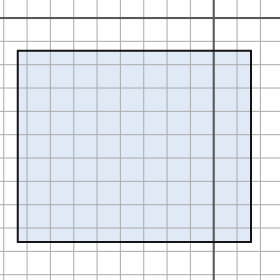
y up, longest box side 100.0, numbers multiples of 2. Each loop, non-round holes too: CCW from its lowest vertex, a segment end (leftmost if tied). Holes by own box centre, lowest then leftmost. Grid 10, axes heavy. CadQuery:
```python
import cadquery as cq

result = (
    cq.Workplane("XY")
    .moveTo(-84.0, -96.0)
    .lineTo(16.0, -96.0)
    .lineTo(16.0, -14.0)
    .lineTo(-84.0, -14.0)
    .close()
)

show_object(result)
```